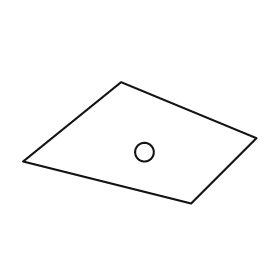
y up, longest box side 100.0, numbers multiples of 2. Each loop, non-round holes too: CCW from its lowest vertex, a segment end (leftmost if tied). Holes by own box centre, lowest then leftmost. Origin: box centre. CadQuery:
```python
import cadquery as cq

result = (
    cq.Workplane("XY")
    .moveTo(22.0, -26.0)
    .lineTo(50.0, 2.0)
    .lineTo(-8.0, 26.0)
    .lineTo(-50.0, -8.0)
    .close()
    .moveTo(2.0, -4.0)
    .circle(4.0)
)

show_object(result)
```